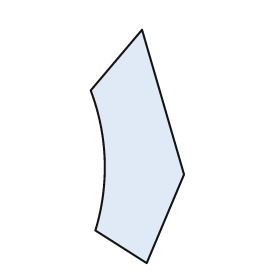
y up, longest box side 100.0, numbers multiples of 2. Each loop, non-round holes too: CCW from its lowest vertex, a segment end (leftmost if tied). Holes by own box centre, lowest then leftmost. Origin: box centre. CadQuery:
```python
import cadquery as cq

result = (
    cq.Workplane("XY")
    .moveTo(4.0, -50.0)
    .lineTo(20.0, -12.0)
    .lineTo(2.0, 50.0)
    .lineTo(-20.0, 24.0)
    .threePointArc((-14.0, -6.0), (-18.0, -36.0))
    .close()
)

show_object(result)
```